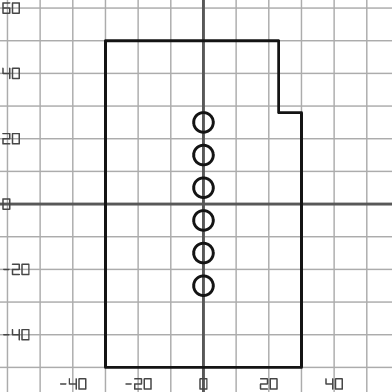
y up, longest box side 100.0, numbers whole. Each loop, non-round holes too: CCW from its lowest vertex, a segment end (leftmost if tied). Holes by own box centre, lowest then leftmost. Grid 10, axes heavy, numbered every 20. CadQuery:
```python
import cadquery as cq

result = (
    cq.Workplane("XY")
    .moveTo(-30.0, -50.0)
    .lineTo(30.0, -50.0)
    .lineTo(30.0, 28.0)
    .lineTo(23.0, 28.0)
    .lineTo(23.0, 50.0)
    .lineTo(-30.0, 50.0)
    .close()
    .moveTo(0.0, -25.0)
    .circle(3.0)
    .moveTo(0.0, -15.0)
    .circle(3.0)
    .moveTo(0.0, -5.0)
    .circle(3.0)
    .moveTo(0.0, 5.0)
    .circle(3.0)
    .moveTo(0.0, 15.0)
    .circle(3.0)
    .moveTo(0.0, 25.0)
    .circle(3.0)
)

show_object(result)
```